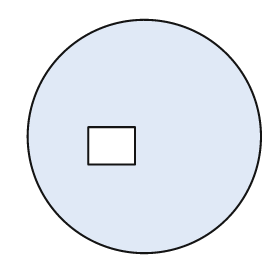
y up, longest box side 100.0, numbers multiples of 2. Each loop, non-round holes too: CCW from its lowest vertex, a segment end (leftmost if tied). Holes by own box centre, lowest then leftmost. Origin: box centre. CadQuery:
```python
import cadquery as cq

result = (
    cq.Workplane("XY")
    .moveTo(0.0, 0.0)
    .circle(50.0)
    .moveTo(-24.0, -12.0)
    .lineTo(-4.0, -12.0)
    .lineTo(-4.0, 4.0)
    .lineTo(-24.0, 4.0)
    .close()
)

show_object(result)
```